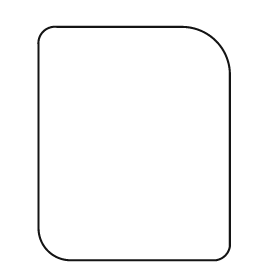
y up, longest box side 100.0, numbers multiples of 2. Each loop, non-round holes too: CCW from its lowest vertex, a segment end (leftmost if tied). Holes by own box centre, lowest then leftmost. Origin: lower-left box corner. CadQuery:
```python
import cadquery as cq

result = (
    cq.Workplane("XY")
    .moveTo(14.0, 0.0)
    .lineTo(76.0, 0.0)
    .threePointArc((80.0, 2.0), (82.0, 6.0))
    .lineTo(82.0, 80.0)
    .threePointArc((76.0, 94.0), (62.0, 100.0))
    .lineTo(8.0, 100.0)
    .threePointArc((2.0, 98.0), (0.0, 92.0))
    .lineTo(0.0, 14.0)
    .threePointArc((4.0, 4.0), (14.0, 0.0))
    .close()
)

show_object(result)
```